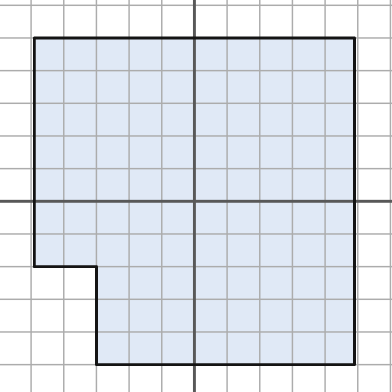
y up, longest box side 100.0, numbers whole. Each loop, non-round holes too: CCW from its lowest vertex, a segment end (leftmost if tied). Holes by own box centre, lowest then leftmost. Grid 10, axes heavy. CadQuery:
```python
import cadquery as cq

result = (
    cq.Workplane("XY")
    .moveTo(-30.0, -50.0)
    .lineTo(49.0, -50.0)
    .lineTo(49.0, 50.0)
    .lineTo(-49.0, 50.0)
    .lineTo(-49.0, -20.0)
    .lineTo(-30.0, -20.0)
    .close()
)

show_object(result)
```